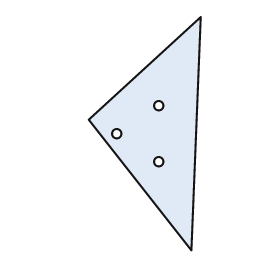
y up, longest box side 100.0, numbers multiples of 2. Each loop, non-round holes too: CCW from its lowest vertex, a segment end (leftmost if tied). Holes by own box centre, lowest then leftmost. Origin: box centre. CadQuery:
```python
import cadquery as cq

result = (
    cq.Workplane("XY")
    .moveTo(20.0, -50.0)
    .lineTo(24.0, 50.0)
    .lineTo(-24.0, 6.0)
    .close()
    .moveTo(6.0, -12.0)
    .circle(2.0)
    .moveTo(-12.0, 0.0)
    .circle(2.0)
    .moveTo(6.0, 12.0)
    .circle(2.0)
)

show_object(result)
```